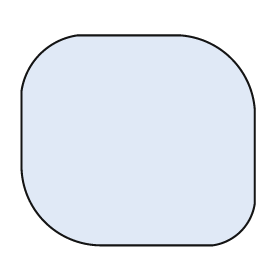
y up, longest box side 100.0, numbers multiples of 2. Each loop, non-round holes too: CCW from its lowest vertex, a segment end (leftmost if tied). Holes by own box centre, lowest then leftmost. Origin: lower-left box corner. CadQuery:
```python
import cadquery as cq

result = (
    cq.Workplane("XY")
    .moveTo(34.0, 0.0)
    .lineTo(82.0, 0.0)
    .threePointArc((94.0, 6.0), (100.0, 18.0))
    .lineTo(100.0, 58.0)
    .threePointArc((90.0, 80.0), (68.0, 90.0))
    .lineTo(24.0, 90.0)
    .threePointArc((8.0, 82.0), (0.0, 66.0))
    .lineTo(0.0, 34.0)
    .threePointArc((10.0, 10.0), (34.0, 0.0))
    .close()
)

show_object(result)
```